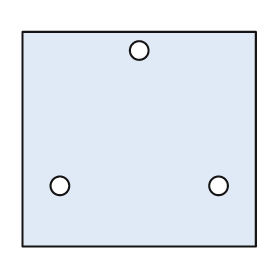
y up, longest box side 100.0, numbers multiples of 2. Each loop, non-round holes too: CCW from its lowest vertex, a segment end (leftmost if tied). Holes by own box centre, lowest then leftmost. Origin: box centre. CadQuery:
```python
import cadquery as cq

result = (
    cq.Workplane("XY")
    .moveTo(-50.0, -46.0)
    .lineTo(50.0, -46.0)
    .lineTo(50.0, 46.0)
    .lineTo(-50.0, 46.0)
    .close()
    .moveTo(-34.0, -20.0)
    .circle(4.0)
    .moveTo(34.0, -20.0)
    .circle(4.0)
    .moveTo(0.0, 38.0)
    .circle(4.0)
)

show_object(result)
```